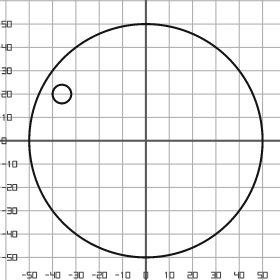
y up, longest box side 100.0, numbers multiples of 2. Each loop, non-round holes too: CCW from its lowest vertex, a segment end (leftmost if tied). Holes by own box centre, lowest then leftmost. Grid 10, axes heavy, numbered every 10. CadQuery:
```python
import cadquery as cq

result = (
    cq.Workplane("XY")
    .moveTo(0.0, 0.0)
    .circle(50.0)
    .moveTo(-36.0, 20.0)
    .circle(4.0)
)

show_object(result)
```